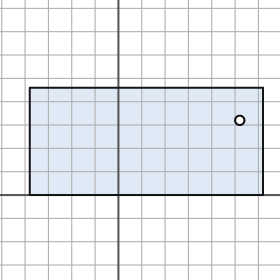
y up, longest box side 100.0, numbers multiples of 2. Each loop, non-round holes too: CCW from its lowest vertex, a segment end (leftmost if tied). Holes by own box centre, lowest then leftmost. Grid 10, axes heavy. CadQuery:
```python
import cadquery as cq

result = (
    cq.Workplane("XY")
    .moveTo(-38.0, 0.0)
    .lineTo(62.0, 0.0)
    .lineTo(62.0, 46.0)
    .lineTo(-38.0, 46.0)
    .close()
    .moveTo(52.0, 32.0)
    .circle(2.0)
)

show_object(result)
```